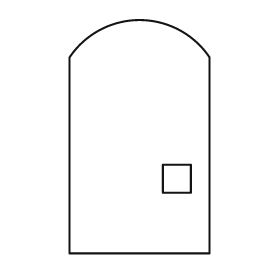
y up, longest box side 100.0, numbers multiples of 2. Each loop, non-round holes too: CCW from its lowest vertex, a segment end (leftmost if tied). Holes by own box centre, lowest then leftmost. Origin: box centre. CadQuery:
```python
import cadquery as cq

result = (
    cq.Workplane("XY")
    .moveTo(-30.0, -50.0)
    .lineTo(30.0, -50.0)
    .lineTo(30.0, 34.0)
    .threePointArc((0.0, 50.0), (-30.0, 34.0))
    .close()
    .moveTo(10.0, -24.0)
    .lineTo(22.0, -24.0)
    .lineTo(22.0, -12.0)
    .lineTo(10.0, -12.0)
    .close()
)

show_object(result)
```